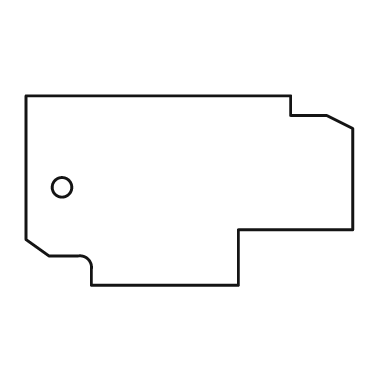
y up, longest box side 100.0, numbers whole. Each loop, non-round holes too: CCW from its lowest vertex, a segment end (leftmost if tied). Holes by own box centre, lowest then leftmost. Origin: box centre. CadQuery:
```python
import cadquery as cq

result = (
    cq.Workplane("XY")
    .moveTo(-30.0, -29.0)
    .lineTo(15.0, -29.0)
    .lineTo(15.0, -12.0)
    .lineTo(50.0, -12.0)
    .lineTo(50.0, 19.0)
    .lineTo(42.0, 23.0)
    .lineTo(31.0, 23.0)
    .lineTo(31.0, 29.0)
    .lineTo(-50.0, 29.0)
    .lineTo(-50.0, -15.0)
    .lineTo(-43.0, -20.0)
    .lineTo(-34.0, -20.0)
    .threePointArc((-31.0, -21.0), (-30.0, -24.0))
    .close()
    .moveTo(-39.0, 1.0)
    .circle(3.0)
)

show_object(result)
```